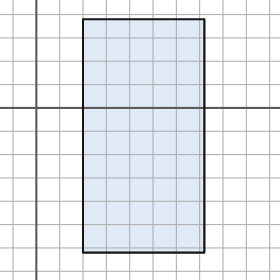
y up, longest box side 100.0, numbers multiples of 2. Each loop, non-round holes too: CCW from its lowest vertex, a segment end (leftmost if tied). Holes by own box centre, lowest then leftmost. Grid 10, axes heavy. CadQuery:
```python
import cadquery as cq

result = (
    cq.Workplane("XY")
    .moveTo(20.0, -62.0)
    .lineTo(72.0, -62.0)
    .lineTo(72.0, 38.0)
    .lineTo(20.0, 38.0)
    .close()
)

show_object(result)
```